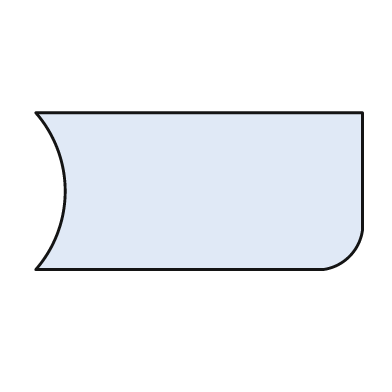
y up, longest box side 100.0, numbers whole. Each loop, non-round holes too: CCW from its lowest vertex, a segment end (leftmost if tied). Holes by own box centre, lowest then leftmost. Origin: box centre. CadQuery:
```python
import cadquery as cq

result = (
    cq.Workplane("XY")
    .moveTo(-50.0, -24.0)
    .lineTo(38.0, -24.0)
    .threePointArc((46.0, -20.0), (50.0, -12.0))
    .lineTo(50.0, 24.0)
    .lineTo(-50.0, 24.0)
    .threePointArc((-41.0, 0.0), (-50.0, -24.0))
    .close()
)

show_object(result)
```